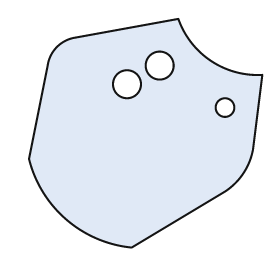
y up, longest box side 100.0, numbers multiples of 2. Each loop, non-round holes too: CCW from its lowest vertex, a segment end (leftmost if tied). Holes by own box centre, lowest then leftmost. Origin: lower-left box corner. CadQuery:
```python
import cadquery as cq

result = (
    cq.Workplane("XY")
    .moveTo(44.0, 0.0)
    .lineTo(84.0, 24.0)
    .threePointArc((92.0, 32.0), (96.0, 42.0))
    .lineTo(100.0, 74.0)
    .threePointArc((78.0, 80.0), (64.0, 98.0))
    .lineTo(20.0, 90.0)
    .threePointArc((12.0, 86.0), (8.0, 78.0))
    .lineTo(0.0, 38.0)
    .threePointArc((16.0, 12.0), (44.0, 0.0))
    .close()
    .moveTo(84.0, 60.0)
    .circle(4.0)
    .moveTo(42.0, 70.0)
    .circle(6.0)
    .moveTo(56.0, 78.0)
    .circle(6.0)
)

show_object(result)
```